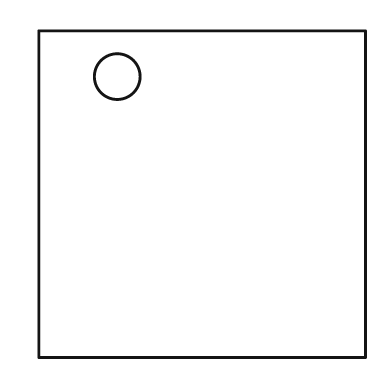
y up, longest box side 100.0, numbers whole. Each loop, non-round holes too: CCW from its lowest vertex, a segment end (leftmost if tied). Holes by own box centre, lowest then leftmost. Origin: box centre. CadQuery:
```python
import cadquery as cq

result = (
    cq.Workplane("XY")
    .moveTo(-50.0, -50.0)
    .lineTo(50.0, -50.0)
    .lineTo(50.0, 50.0)
    .lineTo(-50.0, 50.0)
    .close()
    .moveTo(-26.0, 36.0)
    .circle(7.0)
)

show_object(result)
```